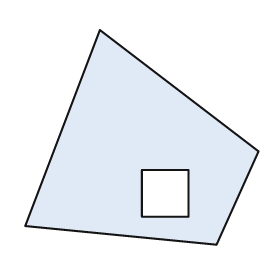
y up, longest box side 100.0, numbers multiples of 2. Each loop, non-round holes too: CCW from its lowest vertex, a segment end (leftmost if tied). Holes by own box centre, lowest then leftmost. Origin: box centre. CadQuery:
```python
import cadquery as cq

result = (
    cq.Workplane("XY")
    .moveTo(32.0, -46.0)
    .lineTo(50.0, -6.0)
    .lineTo(-18.0, 46.0)
    .lineTo(-50.0, -38.0)
    .close()
    .moveTo(0.0, -34.0)
    .lineTo(20.0, -34.0)
    .lineTo(20.0, -14.0)
    .lineTo(0.0, -14.0)
    .close()
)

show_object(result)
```